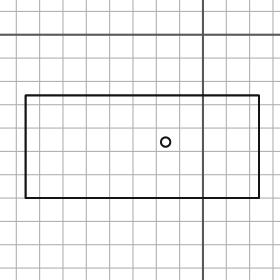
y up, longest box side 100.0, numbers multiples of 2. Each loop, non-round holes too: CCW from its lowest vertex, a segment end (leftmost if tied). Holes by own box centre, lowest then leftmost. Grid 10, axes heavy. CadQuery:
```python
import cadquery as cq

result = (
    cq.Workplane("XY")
    .moveTo(-76.0, -70.0)
    .lineTo(24.0, -70.0)
    .lineTo(24.0, -26.0)
    .lineTo(-76.0, -26.0)
    .close()
    .moveTo(-16.0, -46.0)
    .circle(2.0)
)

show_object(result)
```